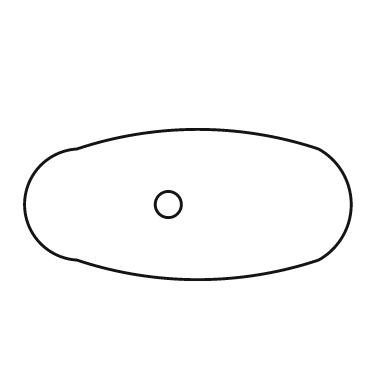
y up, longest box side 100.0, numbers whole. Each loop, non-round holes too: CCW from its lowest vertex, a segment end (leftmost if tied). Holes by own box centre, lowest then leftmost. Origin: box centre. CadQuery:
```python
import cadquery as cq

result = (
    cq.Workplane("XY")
    .moveTo(-34.0, -17.0)
    .threePointArc((3.0, -23.0), (40.0, -17.0))
    .threePointArc((50.0, 0.0), (40.0, 17.0))
    .threePointArc((3.0, 23.0), (-34.0, 17.0))
    .threePointArc((-50.0, 0.0), (-34.0, -17.0))
    .close()
    .moveTo(-6.0, 0.0)
    .circle(4.0)
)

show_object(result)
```